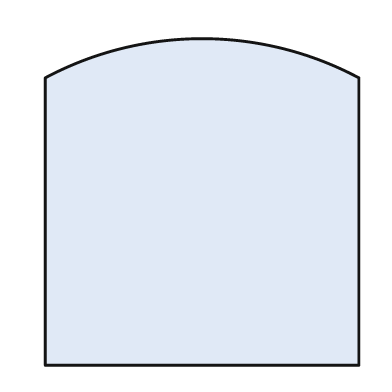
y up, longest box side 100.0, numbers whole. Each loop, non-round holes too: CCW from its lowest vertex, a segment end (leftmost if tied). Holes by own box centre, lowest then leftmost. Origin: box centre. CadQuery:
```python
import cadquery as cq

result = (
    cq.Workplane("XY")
    .moveTo(-48.0, -50.0)
    .lineTo(48.0, -50.0)
    .lineTo(48.0, 38.0)
    .threePointArc((0.0, 50.0), (-48.0, 38.0))
    .close()
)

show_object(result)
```